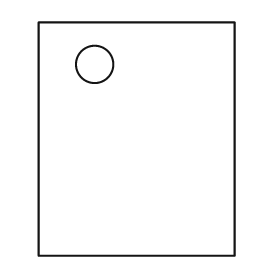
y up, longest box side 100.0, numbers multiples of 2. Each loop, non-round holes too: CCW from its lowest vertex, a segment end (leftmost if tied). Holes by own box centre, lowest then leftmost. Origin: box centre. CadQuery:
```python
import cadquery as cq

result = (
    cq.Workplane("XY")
    .moveTo(-42.0, -50.0)
    .lineTo(42.0, -50.0)
    .lineTo(42.0, 50.0)
    .lineTo(-42.0, 50.0)
    .close()
    .moveTo(-18.0, 32.0)
    .circle(8.0)
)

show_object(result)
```